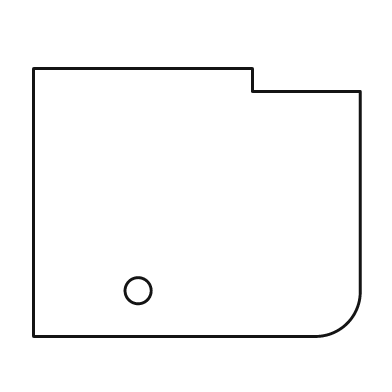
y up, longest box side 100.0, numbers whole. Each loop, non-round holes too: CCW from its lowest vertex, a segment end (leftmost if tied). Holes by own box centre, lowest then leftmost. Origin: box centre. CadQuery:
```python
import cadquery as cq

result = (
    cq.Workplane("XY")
    .moveTo(-50.0, -41.0)
    .lineTo(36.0, -41.0)
    .threePointArc((46.0, -37.0), (50.0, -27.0))
    .lineTo(50.0, 34.0)
    .lineTo(17.0, 34.0)
    .lineTo(17.0, 41.0)
    .lineTo(-50.0, 41.0)
    .close()
    .moveTo(-18.0, -27.0)
    .circle(4.0)
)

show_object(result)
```